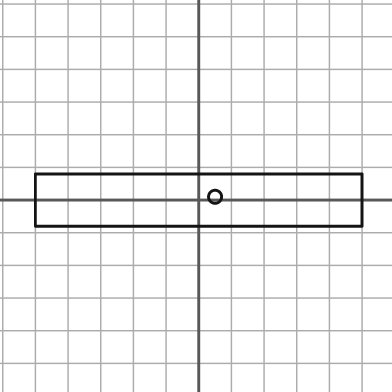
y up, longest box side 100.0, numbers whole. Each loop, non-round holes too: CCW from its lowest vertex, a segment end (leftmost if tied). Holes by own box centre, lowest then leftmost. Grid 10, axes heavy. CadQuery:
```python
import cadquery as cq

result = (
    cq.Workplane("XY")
    .moveTo(-50.0, -8.0)
    .lineTo(50.0, -8.0)
    .lineTo(50.0, 8.0)
    .lineTo(-50.0, 8.0)
    .close()
    .moveTo(5.0, 1.0)
    .circle(2.0)
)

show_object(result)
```